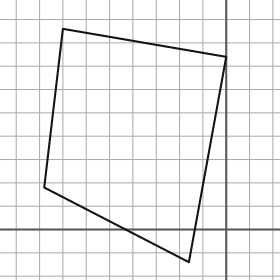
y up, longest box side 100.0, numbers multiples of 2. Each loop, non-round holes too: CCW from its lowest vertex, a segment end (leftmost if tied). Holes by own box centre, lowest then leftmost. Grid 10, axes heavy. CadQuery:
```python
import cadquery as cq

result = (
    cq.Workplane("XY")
    .moveTo(-16.0, -14.0)
    .lineTo(0.0, 74.0)
    .lineTo(-70.0, 86.0)
    .lineTo(-78.0, 18.0)
    .close()
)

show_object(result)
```